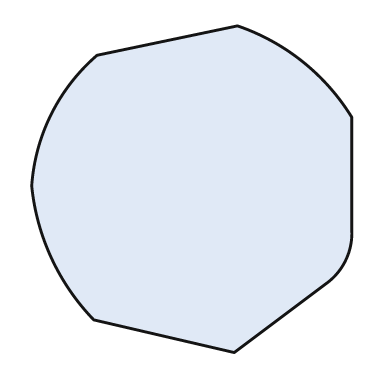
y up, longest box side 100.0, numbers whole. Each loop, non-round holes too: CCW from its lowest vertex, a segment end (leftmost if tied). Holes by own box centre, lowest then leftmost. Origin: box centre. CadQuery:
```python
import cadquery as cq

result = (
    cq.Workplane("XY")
    .moveTo(13.0, -50.0)
    .lineTo(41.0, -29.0)
    .threePointArc((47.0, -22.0), (49.0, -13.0))
    .lineTo(49.0, 22.0)
    .threePointArc((34.0, 39.0), (14.0, 50.0))
    .lineTo(-29.0, 41.0)
    .threePointArc((-43.0, 23.0), (-49.0, 1.0))
    .threePointArc((-43.0, -21.0), (-30.0, -40.0))
    .close()
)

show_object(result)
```